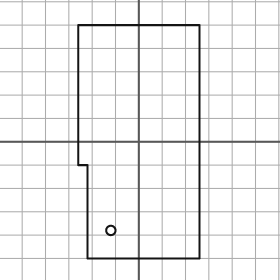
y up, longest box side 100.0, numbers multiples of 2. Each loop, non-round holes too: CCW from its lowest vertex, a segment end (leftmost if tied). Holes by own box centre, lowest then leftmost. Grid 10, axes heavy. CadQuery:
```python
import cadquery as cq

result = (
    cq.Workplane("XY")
    .moveTo(-22.0, -50.0)
    .lineTo(26.0, -50.0)
    .lineTo(26.0, 50.0)
    .lineTo(-26.0, 50.0)
    .lineTo(-26.0, -10.0)
    .lineTo(-22.0, -10.0)
    .close()
    .moveTo(-12.0, -38.0)
    .circle(2.0)
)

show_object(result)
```